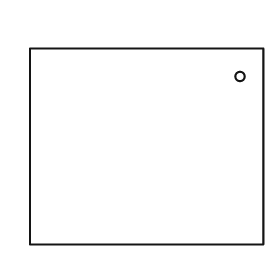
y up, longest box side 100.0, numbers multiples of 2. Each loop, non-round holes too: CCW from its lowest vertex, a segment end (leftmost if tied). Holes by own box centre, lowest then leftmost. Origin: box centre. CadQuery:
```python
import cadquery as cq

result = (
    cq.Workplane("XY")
    .moveTo(-50.0, -42.0)
    .lineTo(50.0, -42.0)
    .lineTo(50.0, 42.0)
    .lineTo(-50.0, 42.0)
    .close()
    .moveTo(40.0, 30.0)
    .circle(2.0)
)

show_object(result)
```